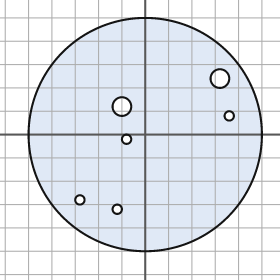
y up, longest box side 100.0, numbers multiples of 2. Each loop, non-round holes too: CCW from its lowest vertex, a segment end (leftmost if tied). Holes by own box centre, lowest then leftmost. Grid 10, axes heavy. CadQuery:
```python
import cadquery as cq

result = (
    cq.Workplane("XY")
    .moveTo(0.0, 0.0)
    .circle(50.0)
    .moveTo(-12.0, -32.0)
    .circle(2.0)
    .moveTo(-28.0, -28.0)
    .circle(2.0)
    .moveTo(-8.0, -2.0)
    .circle(2.0)
    .moveTo(36.0, 8.0)
    .circle(2.0)
    .moveTo(-10.0, 12.0)
    .circle(4.0)
    .moveTo(32.0, 24.0)
    .circle(4.0)
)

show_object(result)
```